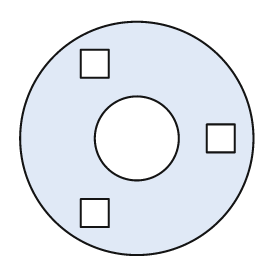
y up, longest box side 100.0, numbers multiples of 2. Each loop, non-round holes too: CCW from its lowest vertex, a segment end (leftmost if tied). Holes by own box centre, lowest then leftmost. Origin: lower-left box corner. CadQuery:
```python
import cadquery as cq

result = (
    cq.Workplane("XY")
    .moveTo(50.0, 50.0)
    .circle(50.0)
    .moveTo(26.0, 12.0)
    .lineTo(38.0, 12.0)
    .lineTo(38.0, 24.0)
    .lineTo(26.0, 24.0)
    .close()
    .moveTo(50.0, 50.0)
    .circle(18.0)
    .moveTo(80.0, 44.0)
    .lineTo(92.0, 44.0)
    .lineTo(92.0, 56.0)
    .lineTo(80.0, 56.0)
    .close()
    .moveTo(26.0, 76.0)
    .lineTo(38.0, 76.0)
    .lineTo(38.0, 88.0)
    .lineTo(26.0, 88.0)
    .close()
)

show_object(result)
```